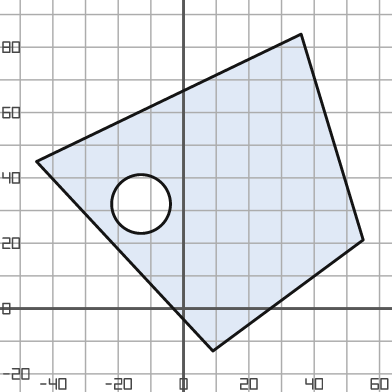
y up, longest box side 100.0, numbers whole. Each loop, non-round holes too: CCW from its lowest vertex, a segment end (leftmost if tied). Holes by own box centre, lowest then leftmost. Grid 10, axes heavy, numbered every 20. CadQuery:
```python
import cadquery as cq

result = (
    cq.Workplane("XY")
    .moveTo(9.0, -13.0)
    .lineTo(55.0, 21.0)
    .lineTo(36.0, 84.0)
    .lineTo(-45.0, 45.0)
    .close()
    .moveTo(-13.0, 32.0)
    .circle(9.0)
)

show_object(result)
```